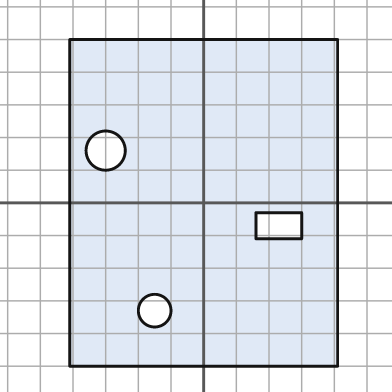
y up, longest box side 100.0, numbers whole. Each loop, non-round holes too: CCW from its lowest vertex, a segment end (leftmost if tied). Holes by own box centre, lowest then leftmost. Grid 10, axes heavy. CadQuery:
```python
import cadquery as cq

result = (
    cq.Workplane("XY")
    .moveTo(-41.0, -50.0)
    .lineTo(41.0, -50.0)
    .lineTo(41.0, 50.0)
    .lineTo(-41.0, 50.0)
    .close()
    .moveTo(-15.0, -33.0)
    .circle(5.0)
    .moveTo(16.0, -11.0)
    .lineTo(30.0, -11.0)
    .lineTo(30.0, -3.0)
    .lineTo(16.0, -3.0)
    .close()
    .moveTo(-30.0, 16.0)
    .circle(6.0)
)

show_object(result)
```